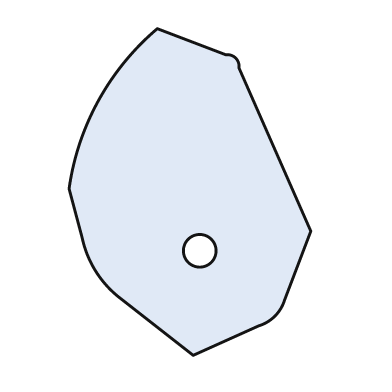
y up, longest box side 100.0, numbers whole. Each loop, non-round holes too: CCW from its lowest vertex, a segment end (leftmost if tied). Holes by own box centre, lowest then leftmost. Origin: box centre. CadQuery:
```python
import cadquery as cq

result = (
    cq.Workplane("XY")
    .moveTo(1.0, -50.0)
    .lineTo(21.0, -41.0)
    .threePointArc((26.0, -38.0), (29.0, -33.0))
    .lineTo(37.0, -12.0)
    .lineTo(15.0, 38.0)
    .threePointArc((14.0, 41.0), (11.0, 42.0))
    .lineTo(-10.0, 50.0)
    .threePointArc((-28.0, 28.0), (-37.0, 1.0))
    .lineTo(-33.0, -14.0)
    .threePointArc((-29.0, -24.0), (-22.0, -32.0))
    .close()
    .moveTo(3.0, -18.0)
    .circle(5.0)
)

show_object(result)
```